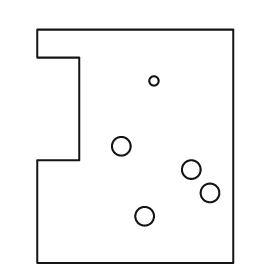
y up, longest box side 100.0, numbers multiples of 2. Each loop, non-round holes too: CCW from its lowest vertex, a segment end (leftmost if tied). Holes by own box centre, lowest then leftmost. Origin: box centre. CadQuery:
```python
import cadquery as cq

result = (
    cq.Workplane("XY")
    .moveTo(-42.0, -50.0)
    .lineTo(42.0, -50.0)
    .lineTo(42.0, 50.0)
    .lineTo(-42.0, 50.0)
    .lineTo(-42.0, 38.0)
    .lineTo(-24.0, 38.0)
    .lineTo(-24.0, -6.0)
    .lineTo(-42.0, -6.0)
    .close()
    .moveTo(4.0, -30.0)
    .circle(4.0)
    .moveTo(32.0, -20.0)
    .circle(4.0)
    .moveTo(24.0, -10.0)
    .circle(4.0)
    .moveTo(-6.0, 0.0)
    .circle(4.0)
    .moveTo(8.0, 28.0)
    .circle(2.0)
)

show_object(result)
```